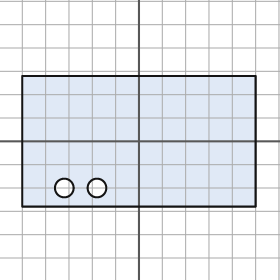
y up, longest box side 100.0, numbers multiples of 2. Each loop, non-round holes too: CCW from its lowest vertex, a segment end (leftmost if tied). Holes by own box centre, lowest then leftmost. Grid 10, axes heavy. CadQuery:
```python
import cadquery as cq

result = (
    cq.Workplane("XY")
    .moveTo(-50.0, -28.0)
    .lineTo(50.0, -28.0)
    .lineTo(50.0, 28.0)
    .lineTo(-50.0, 28.0)
    .close()
    .moveTo(-32.0, -20.0)
    .circle(4.0)
    .moveTo(-18.0, -20.0)
    .circle(4.0)
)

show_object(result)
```